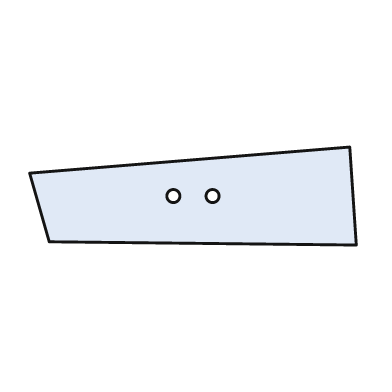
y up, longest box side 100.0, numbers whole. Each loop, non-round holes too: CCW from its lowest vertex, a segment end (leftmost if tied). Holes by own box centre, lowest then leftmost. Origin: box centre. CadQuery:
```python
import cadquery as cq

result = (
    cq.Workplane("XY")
    .moveTo(50.0, -15.0)
    .lineTo(48.0, 15.0)
    .lineTo(-50.0, 7.0)
    .lineTo(-44.0, -14.0)
    .close()
    .moveTo(-6.0, 0.0)
    .circle(2.0)
    .moveTo(6.0, 0.0)
    .circle(2.0)
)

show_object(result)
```